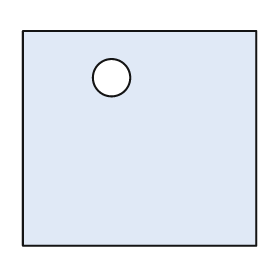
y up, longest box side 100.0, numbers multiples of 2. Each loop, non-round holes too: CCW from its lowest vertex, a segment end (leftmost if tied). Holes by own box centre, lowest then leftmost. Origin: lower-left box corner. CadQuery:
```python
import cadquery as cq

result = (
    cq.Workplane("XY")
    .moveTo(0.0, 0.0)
    .lineTo(100.0, 0.0)
    .lineTo(100.0, 92.0)
    .lineTo(0.0, 92.0)
    .close()
    .moveTo(38.0, 72.0)
    .circle(8.0)
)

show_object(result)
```